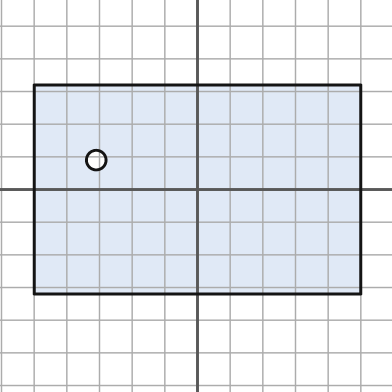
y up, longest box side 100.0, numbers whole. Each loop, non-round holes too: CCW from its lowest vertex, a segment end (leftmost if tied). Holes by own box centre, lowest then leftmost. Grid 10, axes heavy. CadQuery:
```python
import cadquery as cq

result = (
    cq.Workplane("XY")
    .moveTo(-50.0, -32.0)
    .lineTo(50.0, -32.0)
    .lineTo(50.0, 32.0)
    .lineTo(-50.0, 32.0)
    .close()
    .moveTo(-31.0, 9.0)
    .circle(3.0)
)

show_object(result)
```